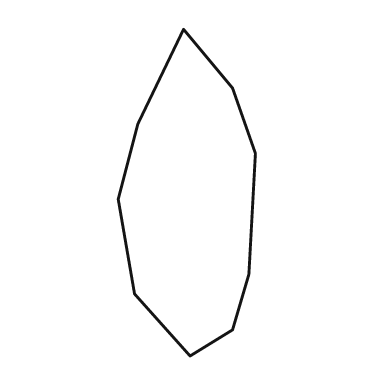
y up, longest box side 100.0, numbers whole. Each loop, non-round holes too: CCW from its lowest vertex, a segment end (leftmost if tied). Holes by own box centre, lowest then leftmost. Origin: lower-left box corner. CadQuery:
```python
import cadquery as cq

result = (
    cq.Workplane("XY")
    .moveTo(22.0, 0.0)
    .lineTo(35.0, 8.0)
    .lineTo(40.0, 25.0)
    .lineTo(42.0, 62.0)
    .lineTo(35.0, 82.0)
    .lineTo(20.0, 100.0)
    .lineTo(6.0, 71.0)
    .lineTo(0.0, 48.0)
    .lineTo(5.0, 19.0)
    .close()
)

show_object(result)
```